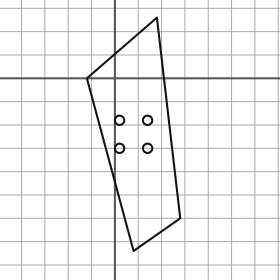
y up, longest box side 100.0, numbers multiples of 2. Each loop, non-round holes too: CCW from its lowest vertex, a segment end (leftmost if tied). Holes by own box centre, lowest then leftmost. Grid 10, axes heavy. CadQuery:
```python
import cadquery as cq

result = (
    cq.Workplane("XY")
    .moveTo(8.0, -74.0)
    .lineTo(28.0, -60.0)
    .lineTo(18.0, 26.0)
    .lineTo(-12.0, 0.0)
    .close()
    .moveTo(2.0, -30.0)
    .circle(2.0)
    .moveTo(14.0, -30.0)
    .circle(2.0)
    .moveTo(2.0, -18.0)
    .circle(2.0)
    .moveTo(14.0, -18.0)
    .circle(2.0)
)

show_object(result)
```